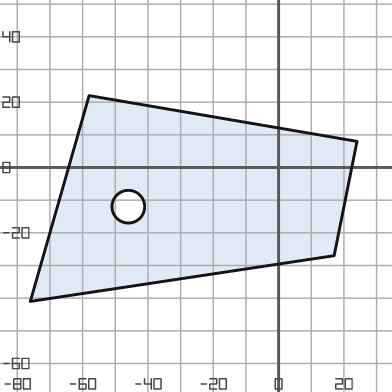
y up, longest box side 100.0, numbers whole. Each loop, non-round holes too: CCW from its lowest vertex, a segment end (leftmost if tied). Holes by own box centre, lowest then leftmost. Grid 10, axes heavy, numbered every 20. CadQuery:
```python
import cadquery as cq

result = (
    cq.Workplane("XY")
    .moveTo(-76.0, -41.0)
    .lineTo(17.0, -27.0)
    .lineTo(24.0, 8.0)
    .lineTo(-58.0, 22.0)
    .close()
    .moveTo(-46.0, -12.0)
    .circle(5.0)
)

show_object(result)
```